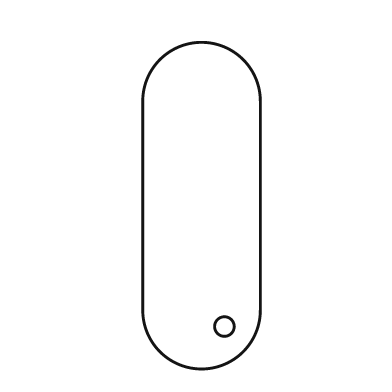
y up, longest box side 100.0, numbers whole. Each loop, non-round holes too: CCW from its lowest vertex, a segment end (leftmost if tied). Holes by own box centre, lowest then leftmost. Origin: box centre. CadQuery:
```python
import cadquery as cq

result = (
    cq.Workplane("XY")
    .moveTo(-18.0, -32.0)
    .threePointArc((0.0, -50.0), (18.0, -32.0))
    .lineTo(18.0, 32.0)
    .threePointArc((0.0, 50.0), (-18.0, 32.0))
    .close()
    .moveTo(7.0, -37.0)
    .circle(3.0)
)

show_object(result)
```